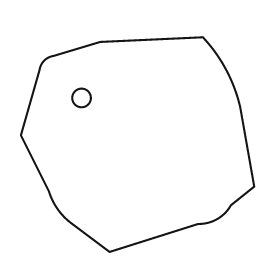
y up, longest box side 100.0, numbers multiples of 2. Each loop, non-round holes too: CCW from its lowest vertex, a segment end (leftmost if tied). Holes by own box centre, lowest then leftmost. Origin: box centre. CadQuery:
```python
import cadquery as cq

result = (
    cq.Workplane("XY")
    .moveTo(-12.0, -46.0)
    .lineTo(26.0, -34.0)
    .threePointArc((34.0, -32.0), (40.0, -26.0))
    .lineTo(50.0, -18.0)
    .lineTo(44.0, 16.0)
    .threePointArc((38.0, 32.0), (28.0, 46.0))
    .lineTo(-16.0, 44.0)
    .lineTo(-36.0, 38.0)
    .threePointArc((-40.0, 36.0), (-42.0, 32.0))
    .lineTo(-50.0, 4.0)
    .lineTo(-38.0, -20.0)
    .threePointArc((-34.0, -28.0), (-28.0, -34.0))
    .close()
    .moveTo(-24.0, 20.0)
    .circle(4.0)
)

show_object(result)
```